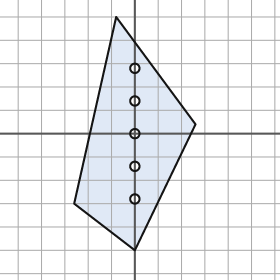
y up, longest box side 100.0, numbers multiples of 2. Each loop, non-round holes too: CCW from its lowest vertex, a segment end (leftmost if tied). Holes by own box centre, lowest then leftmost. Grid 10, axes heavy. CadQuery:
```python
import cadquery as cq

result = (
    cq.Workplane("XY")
    .moveTo(0.0, -50.0)
    .lineTo(26.0, 4.0)
    .lineTo(-8.0, 50.0)
    .lineTo(-26.0, -30.0)
    .close()
    .moveTo(0.0, -28.0)
    .circle(2.0)
    .moveTo(0.0, -14.0)
    .circle(2.0)
    .moveTo(0.0, 0.0)
    .circle(2.0)
    .moveTo(0.0, 14.0)
    .circle(2.0)
    .moveTo(0.0, 28.0)
    .circle(2.0)
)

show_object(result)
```